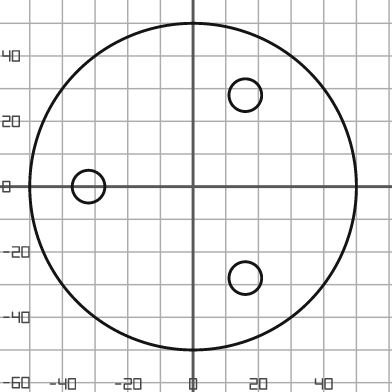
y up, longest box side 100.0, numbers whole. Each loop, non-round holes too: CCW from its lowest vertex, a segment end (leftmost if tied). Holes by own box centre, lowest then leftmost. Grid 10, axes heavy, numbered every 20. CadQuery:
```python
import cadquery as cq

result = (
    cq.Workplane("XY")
    .moveTo(0.0, 0.0)
    .circle(50.0)
    .moveTo(16.0, -28.0)
    .circle(5.0)
    .moveTo(-32.0, 0.0)
    .circle(5.0)
    .moveTo(16.0, 28.0)
    .circle(5.0)
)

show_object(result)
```